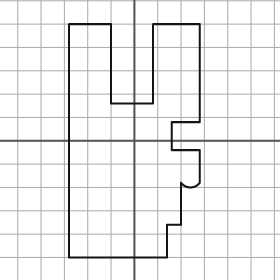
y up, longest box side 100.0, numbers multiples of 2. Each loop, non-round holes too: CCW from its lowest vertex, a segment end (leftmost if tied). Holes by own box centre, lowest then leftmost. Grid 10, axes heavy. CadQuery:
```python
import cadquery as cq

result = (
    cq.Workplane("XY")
    .moveTo(-28.0, -50.0)
    .lineTo(14.0, -50.0)
    .lineTo(14.0, -36.0)
    .lineTo(20.0, -36.0)
    .lineTo(20.0, -18.0)
    .threePointArc((24.0, -20.0), (28.0, -18.0))
    .lineTo(28.0, -4.0)
    .lineTo(16.0, -4.0)
    .lineTo(16.0, 8.0)
    .lineTo(28.0, 8.0)
    .lineTo(28.0, 50.0)
    .lineTo(8.0, 50.0)
    .lineTo(8.0, 16.0)
    .lineTo(-10.0, 16.0)
    .lineTo(-10.0, 50.0)
    .lineTo(-28.0, 50.0)
    .close()
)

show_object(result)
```